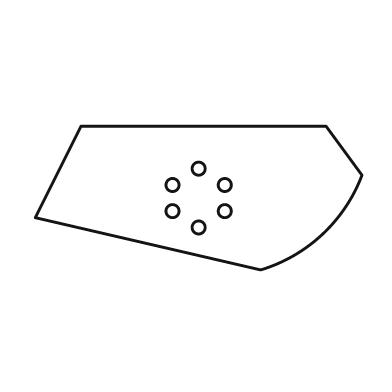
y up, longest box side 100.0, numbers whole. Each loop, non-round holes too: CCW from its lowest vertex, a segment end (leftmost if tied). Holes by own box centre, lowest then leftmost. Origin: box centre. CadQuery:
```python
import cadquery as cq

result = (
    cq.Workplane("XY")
    .moveTo(19.0, -22.0)
    .threePointArc((38.0, -11.0), (50.0, 7.0))
    .lineTo(39.0, 22.0)
    .lineTo(-36.0, 22.0)
    .lineTo(-50.0, -6.0)
    .close()
    .moveTo(0.0, -9.0)
    .circle(2.0)
    .moveTo(-8.0, -4.0)
    .circle(2.0)
    .moveTo(8.0, -4.0)
    .circle(2.0)
    .moveTo(-8.0, 4.0)
    .circle(2.0)
    .moveTo(8.0, 4.0)
    .circle(2.0)
    .moveTo(0.0, 9.0)
    .circle(2.0)
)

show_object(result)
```